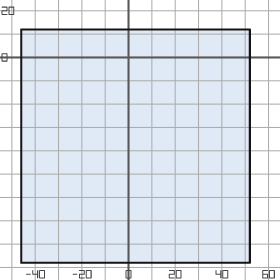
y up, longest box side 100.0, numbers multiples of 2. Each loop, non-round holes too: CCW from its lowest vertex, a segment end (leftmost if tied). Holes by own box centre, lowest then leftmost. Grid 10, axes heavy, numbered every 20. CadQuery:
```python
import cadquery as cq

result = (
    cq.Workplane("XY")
    .moveTo(-46.0, -88.0)
    .lineTo(52.0, -88.0)
    .lineTo(52.0, 12.0)
    .lineTo(-46.0, 12.0)
    .close()
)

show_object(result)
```